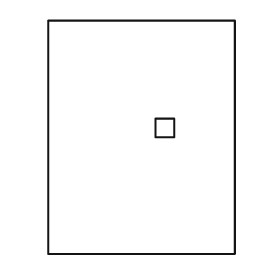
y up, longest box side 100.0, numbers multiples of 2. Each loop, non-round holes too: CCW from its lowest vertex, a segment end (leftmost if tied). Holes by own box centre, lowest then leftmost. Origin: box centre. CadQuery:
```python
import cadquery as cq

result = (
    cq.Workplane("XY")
    .moveTo(-40.0, -50.0)
    .lineTo(40.0, -50.0)
    .lineTo(40.0, 50.0)
    .lineTo(-40.0, 50.0)
    .close()
    .moveTo(6.0, 0.0)
    .lineTo(14.0, 0.0)
    .lineTo(14.0, 8.0)
    .lineTo(6.0, 8.0)
    .close()
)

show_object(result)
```